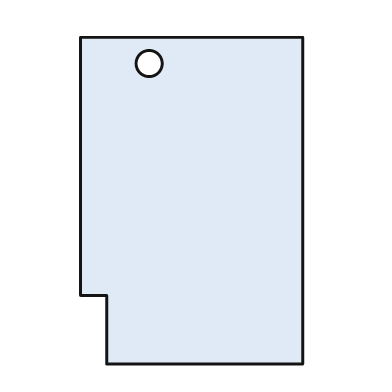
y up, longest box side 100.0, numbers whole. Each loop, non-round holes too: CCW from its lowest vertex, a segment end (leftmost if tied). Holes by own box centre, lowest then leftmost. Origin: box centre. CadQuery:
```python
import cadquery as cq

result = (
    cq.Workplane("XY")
    .moveTo(-26.0, -50.0)
    .lineTo(34.0, -50.0)
    .lineTo(34.0, 50.0)
    .lineTo(-34.0, 50.0)
    .lineTo(-34.0, -29.0)
    .lineTo(-26.0, -29.0)
    .close()
    .moveTo(-13.0, 42.0)
    .circle(4.0)
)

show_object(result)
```